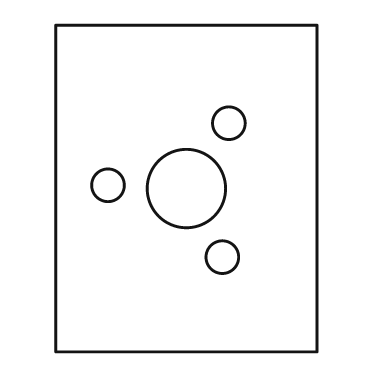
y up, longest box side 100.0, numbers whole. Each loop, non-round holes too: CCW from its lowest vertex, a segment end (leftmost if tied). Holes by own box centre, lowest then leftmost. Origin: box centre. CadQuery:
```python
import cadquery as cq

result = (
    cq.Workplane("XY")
    .moveTo(-40.0, -50.0)
    .lineTo(40.0, -50.0)
    .lineTo(40.0, 50.0)
    .lineTo(-40.0, 50.0)
    .close()
    .moveTo(11.0, -21.0)
    .circle(5.0)
    .moveTo(0.0, 0.0)
    .circle(12.0)
    .moveTo(-24.0, 1.0)
    .circle(5.0)
    .moveTo(13.0, 20.0)
    .circle(5.0)
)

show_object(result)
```